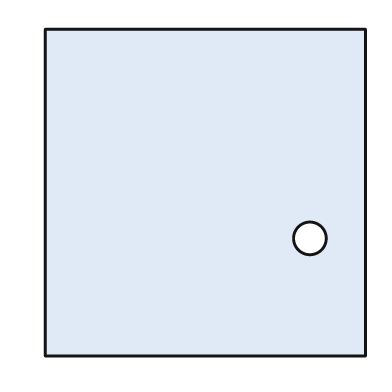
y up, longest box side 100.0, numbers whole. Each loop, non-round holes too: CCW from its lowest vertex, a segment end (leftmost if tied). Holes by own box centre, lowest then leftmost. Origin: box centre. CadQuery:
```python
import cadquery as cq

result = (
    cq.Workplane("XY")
    .moveTo(-49.0, -50.0)
    .lineTo(49.0, -50.0)
    .lineTo(49.0, 50.0)
    .lineTo(-49.0, 50.0)
    .close()
    .moveTo(32.0, -14.0)
    .circle(5.0)
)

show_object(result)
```